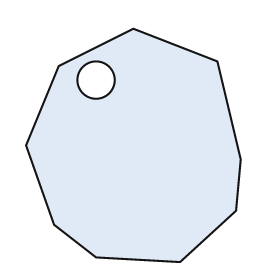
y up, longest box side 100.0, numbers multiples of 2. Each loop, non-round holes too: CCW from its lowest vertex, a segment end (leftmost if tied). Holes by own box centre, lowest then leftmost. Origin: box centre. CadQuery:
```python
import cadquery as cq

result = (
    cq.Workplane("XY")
    .moveTo(20.0, -50.0)
    .lineTo(44.0, -28.0)
    .lineTo(46.0, -6.0)
    .lineTo(36.0, 36.0)
    .lineTo(0.0, 50.0)
    .lineTo(-32.0, 34.0)
    .lineTo(-46.0, 0.0)
    .lineTo(-34.0, -34.0)
    .lineTo(-16.0, -48.0)
    .close()
    .moveTo(-16.0, 28.0)
    .circle(8.0)
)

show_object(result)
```